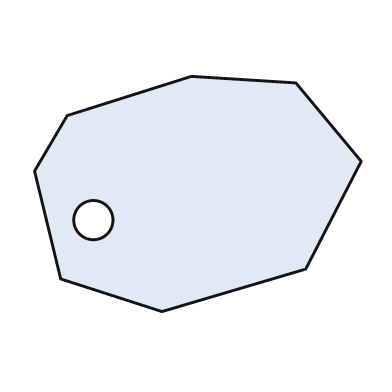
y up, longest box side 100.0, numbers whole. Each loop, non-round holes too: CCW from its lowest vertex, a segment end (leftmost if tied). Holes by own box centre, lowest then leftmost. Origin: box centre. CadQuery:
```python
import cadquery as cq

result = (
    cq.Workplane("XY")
    .moveTo(-11.0, -36.0)
    .lineTo(33.0, -23.0)
    .lineTo(50.0, 10.0)
    .lineTo(30.0, 34.0)
    .lineTo(-2.0, 36.0)
    .lineTo(-40.0, 24.0)
    .lineTo(-50.0, 7.0)
    .lineTo(-42.0, -26.0)
    .close()
    .moveTo(-32.0, -8.0)
    .circle(6.0)
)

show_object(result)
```